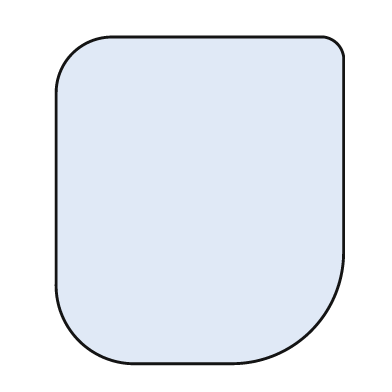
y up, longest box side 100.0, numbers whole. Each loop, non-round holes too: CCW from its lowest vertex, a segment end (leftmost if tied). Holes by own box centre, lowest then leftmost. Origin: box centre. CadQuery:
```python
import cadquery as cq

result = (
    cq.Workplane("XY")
    .moveTo(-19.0, -50.0)
    .lineTo(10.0, -50.0)
    .threePointArc((34.0, -40.0), (44.0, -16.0))
    .lineTo(44.0, 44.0)
    .threePointArc((42.0, 48.0), (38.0, 50.0))
    .lineTo(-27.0, 50.0)
    .threePointArc((-39.0, 45.0), (-44.0, 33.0))
    .lineTo(-44.0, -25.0)
    .threePointArc((-37.0, -43.0), (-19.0, -50.0))
    .close()
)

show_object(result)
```